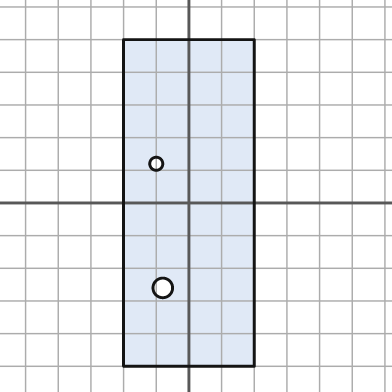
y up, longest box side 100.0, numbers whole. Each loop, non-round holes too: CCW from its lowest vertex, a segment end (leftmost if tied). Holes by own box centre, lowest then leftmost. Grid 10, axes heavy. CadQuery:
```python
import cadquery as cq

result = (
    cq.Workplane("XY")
    .moveTo(-20.0, -50.0)
    .lineTo(20.0, -50.0)
    .lineTo(20.0, 50.0)
    .lineTo(-20.0, 50.0)
    .close()
    .moveTo(-8.0, -26.0)
    .circle(3.0)
    .moveTo(-10.0, 12.0)
    .circle(2.0)
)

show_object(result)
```